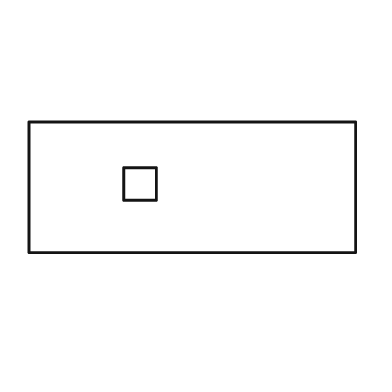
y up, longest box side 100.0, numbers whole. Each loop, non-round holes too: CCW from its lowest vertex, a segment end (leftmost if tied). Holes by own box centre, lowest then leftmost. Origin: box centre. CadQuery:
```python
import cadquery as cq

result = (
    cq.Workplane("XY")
    .moveTo(-50.0, -20.0)
    .lineTo(50.0, -20.0)
    .lineTo(50.0, 20.0)
    .lineTo(-50.0, 20.0)
    .close()
    .moveTo(-21.0, -4.0)
    .lineTo(-11.0, -4.0)
    .lineTo(-11.0, 6.0)
    .lineTo(-21.0, 6.0)
    .close()
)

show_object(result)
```